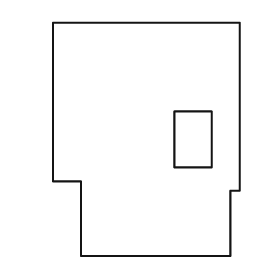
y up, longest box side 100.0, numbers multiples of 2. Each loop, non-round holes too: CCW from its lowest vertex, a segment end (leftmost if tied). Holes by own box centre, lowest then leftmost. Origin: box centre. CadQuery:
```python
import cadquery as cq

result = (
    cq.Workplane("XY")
    .moveTo(-28.0, -50.0)
    .lineTo(36.0, -50.0)
    .lineTo(36.0, -22.0)
    .lineTo(40.0, -22.0)
    .lineTo(40.0, 50.0)
    .lineTo(-40.0, 50.0)
    .lineTo(-40.0, -18.0)
    .lineTo(-28.0, -18.0)
    .close()
    .moveTo(12.0, -12.0)
    .lineTo(28.0, -12.0)
    .lineTo(28.0, 12.0)
    .lineTo(12.0, 12.0)
    .close()
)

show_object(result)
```